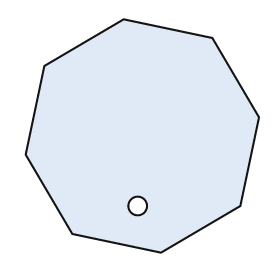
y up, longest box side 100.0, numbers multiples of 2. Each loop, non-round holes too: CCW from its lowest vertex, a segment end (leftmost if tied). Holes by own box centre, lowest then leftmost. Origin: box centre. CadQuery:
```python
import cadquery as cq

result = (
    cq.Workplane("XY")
    .moveTo(8.0, -50.0)
    .lineTo(42.0, -30.0)
    .lineTo(50.0, 8.0)
    .lineTo(30.0, 42.0)
    .lineTo(-8.0, 50.0)
    .lineTo(-42.0, 30.0)
    .lineTo(-50.0, -8.0)
    .lineTo(-30.0, -42.0)
    .close()
    .moveTo(-2.0, -30.0)
    .circle(4.0)
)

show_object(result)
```